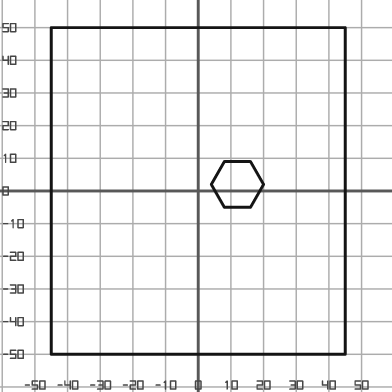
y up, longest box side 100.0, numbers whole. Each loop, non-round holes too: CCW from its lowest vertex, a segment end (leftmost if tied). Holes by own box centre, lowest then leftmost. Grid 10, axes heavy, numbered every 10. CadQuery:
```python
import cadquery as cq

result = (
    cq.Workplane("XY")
    .moveTo(-45.0, -50.0)
    .lineTo(45.0, -50.0)
    .lineTo(45.0, 50.0)
    .lineTo(-45.0, 50.0)
    .close()
    .moveTo(8.0, -5.0)
    .lineTo(16.0, -5.0)
    .lineTo(20.0, 2.0)
    .lineTo(16.0, 9.0)
    .lineTo(8.0, 9.0)
    .lineTo(4.0, 2.0)
    .close()
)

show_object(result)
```